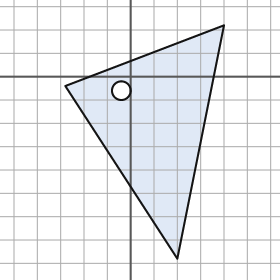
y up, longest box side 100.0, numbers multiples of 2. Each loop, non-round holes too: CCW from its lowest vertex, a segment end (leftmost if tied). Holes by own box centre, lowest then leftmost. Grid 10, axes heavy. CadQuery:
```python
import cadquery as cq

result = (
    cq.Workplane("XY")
    .moveTo(20.0, -78.0)
    .lineTo(40.0, 22.0)
    .lineTo(-28.0, -4.0)
    .close()
    .moveTo(-4.0, -6.0)
    .circle(4.0)
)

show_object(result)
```